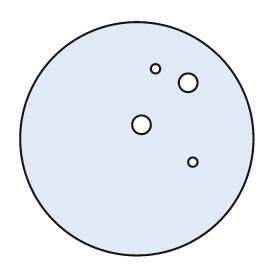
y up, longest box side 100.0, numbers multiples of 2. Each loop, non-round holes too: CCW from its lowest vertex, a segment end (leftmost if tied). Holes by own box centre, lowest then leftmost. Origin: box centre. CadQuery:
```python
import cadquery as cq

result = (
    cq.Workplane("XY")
    .moveTo(0.0, 0.0)
    .circle(50.0)
    .moveTo(24.0, -10.0)
    .circle(2.0)
    .moveTo(2.0, 6.0)
    .circle(4.0)
    .moveTo(22.0, 24.0)
    .circle(4.0)
    .moveTo(8.0, 30.0)
    .circle(2.0)
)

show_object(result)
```